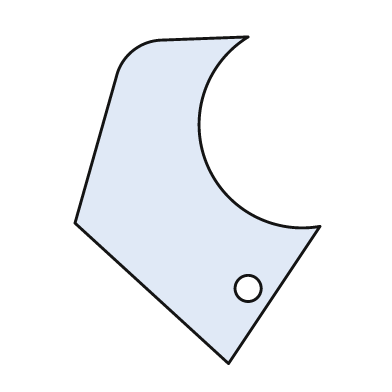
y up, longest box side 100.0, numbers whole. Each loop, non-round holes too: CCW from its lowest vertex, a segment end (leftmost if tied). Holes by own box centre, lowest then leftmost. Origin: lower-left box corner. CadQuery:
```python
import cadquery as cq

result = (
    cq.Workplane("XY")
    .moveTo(47.0, 0.0)
    .lineTo(75.0, 42.0)
    .threePointArc((40.0, 62.0), (53.0, 100.0))
    .lineTo(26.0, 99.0)
    .threePointArc((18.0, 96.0), (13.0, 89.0))
    .lineTo(0.0, 43.0)
    .close()
    .moveTo(53.0, 23.0)
    .circle(4.0)
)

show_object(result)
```